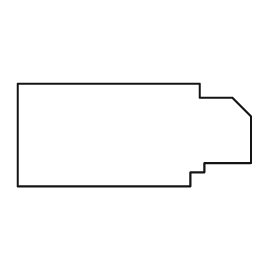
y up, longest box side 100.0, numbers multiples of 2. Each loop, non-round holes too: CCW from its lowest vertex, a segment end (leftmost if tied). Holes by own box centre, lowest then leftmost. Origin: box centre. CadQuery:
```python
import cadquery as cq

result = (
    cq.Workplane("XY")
    .moveTo(-50.0, -22.0)
    .lineTo(24.0, -22.0)
    .lineTo(24.0, -16.0)
    .lineTo(30.0, -16.0)
    .lineTo(30.0, -12.0)
    .lineTo(50.0, -12.0)
    .lineTo(50.0, 8.0)
    .lineTo(42.0, 16.0)
    .lineTo(28.0, 16.0)
    .lineTo(28.0, 22.0)
    .lineTo(-50.0, 22.0)
    .close()
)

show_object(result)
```